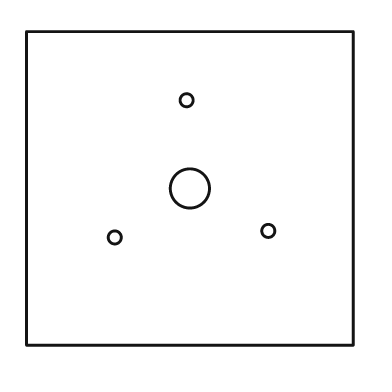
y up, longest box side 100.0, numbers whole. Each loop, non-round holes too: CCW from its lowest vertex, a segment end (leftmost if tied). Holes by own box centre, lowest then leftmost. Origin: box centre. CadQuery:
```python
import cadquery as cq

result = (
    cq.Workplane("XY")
    .moveTo(-50.0, -48.0)
    .lineTo(50.0, -48.0)
    .lineTo(50.0, 48.0)
    .lineTo(-50.0, 48.0)
    .close()
    .moveTo(-23.0, -15.0)
    .circle(2.0)
    .moveTo(24.0, -13.0)
    .circle(2.0)
    .moveTo(0.0, 0.0)
    .circle(6.0)
    .moveTo(-1.0, 27.0)
    .circle(2.0)
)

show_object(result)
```